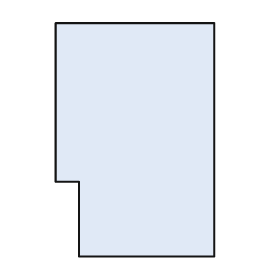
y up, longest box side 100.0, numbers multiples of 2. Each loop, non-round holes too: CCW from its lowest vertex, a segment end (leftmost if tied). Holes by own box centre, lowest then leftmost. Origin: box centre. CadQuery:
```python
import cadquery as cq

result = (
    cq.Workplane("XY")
    .moveTo(-24.0, -50.0)
    .lineTo(34.0, -50.0)
    .lineTo(34.0, 50.0)
    .lineTo(-34.0, 50.0)
    .lineTo(-34.0, -18.0)
    .lineTo(-24.0, -18.0)
    .close()
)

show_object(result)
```